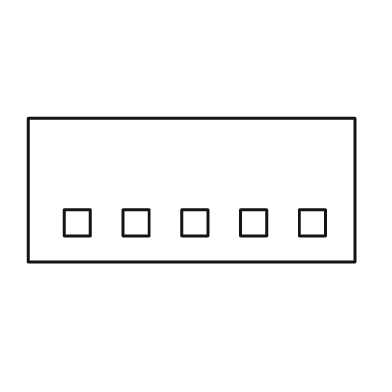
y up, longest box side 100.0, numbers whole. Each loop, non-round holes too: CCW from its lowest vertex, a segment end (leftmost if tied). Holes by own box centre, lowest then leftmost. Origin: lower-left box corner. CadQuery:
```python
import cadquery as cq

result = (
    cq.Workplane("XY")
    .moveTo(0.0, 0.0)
    .lineTo(100.0, 0.0)
    .lineTo(100.0, 44.0)
    .lineTo(0.0, 44.0)
    .close()
    .moveTo(11.0, 8.0)
    .lineTo(19.0, 8.0)
    .lineTo(19.0, 16.0)
    .lineTo(11.0, 16.0)
    .close()
    .moveTo(29.0, 8.0)
    .lineTo(37.0, 8.0)
    .lineTo(37.0, 16.0)
    .lineTo(29.0, 16.0)
    .close()
    .moveTo(47.0, 8.0)
    .lineTo(55.0, 8.0)
    .lineTo(55.0, 16.0)
    .lineTo(47.0, 16.0)
    .close()
    .moveTo(65.0, 8.0)
    .lineTo(73.0, 8.0)
    .lineTo(73.0, 16.0)
    .lineTo(65.0, 16.0)
    .close()
    .moveTo(83.0, 8.0)
    .lineTo(91.0, 8.0)
    .lineTo(91.0, 16.0)
    .lineTo(83.0, 16.0)
    .close()
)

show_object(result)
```